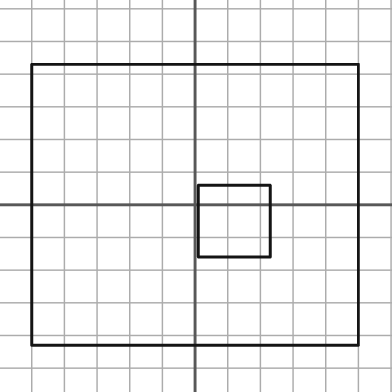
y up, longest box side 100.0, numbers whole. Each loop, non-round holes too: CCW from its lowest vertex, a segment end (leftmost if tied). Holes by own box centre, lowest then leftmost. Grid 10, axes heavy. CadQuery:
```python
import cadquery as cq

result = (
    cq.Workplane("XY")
    .moveTo(-50.0, -43.0)
    .lineTo(50.0, -43.0)
    .lineTo(50.0, 43.0)
    .lineTo(-50.0, 43.0)
    .close()
    .moveTo(1.0, -16.0)
    .lineTo(23.0, -16.0)
    .lineTo(23.0, 6.0)
    .lineTo(1.0, 6.0)
    .close()
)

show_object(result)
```